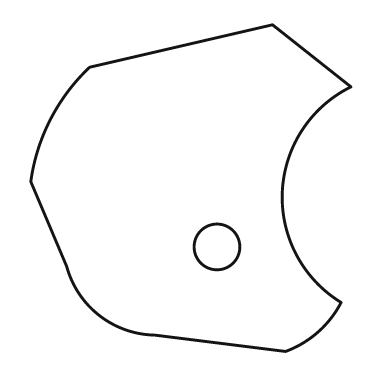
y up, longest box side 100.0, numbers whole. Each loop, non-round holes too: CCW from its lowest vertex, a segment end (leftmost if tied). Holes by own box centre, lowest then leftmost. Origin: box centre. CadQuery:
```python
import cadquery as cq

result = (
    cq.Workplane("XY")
    .moveTo(29.0, -50.0)
    .threePointArc((39.0, -44.0), (46.0, -35.0))
    .threePointArc((28.0, -1.0), (49.0, 31.0))
    .lineTo(25.0, 50.0)
    .lineTo(-31.0, 37.0)
    .threePointArc((-43.0, 21.0), (-49.0, 2.0))
    .lineTo(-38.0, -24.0)
    .threePointArc((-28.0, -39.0), (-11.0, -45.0))
    .close()
    .moveTo(8.0, -18.0)
    .circle(7.0)
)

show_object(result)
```